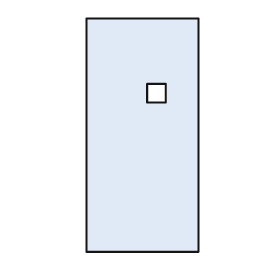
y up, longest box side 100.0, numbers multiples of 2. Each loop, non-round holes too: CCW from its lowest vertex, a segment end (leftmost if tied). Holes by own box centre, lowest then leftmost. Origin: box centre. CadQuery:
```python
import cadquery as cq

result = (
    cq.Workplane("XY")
    .moveTo(-24.0, -50.0)
    .lineTo(24.0, -50.0)
    .lineTo(24.0, 50.0)
    .lineTo(-24.0, 50.0)
    .close()
    .moveTo(2.0, 14.0)
    .lineTo(10.0, 14.0)
    .lineTo(10.0, 22.0)
    .lineTo(2.0, 22.0)
    .close()
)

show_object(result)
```